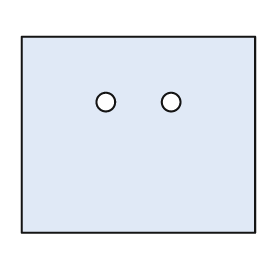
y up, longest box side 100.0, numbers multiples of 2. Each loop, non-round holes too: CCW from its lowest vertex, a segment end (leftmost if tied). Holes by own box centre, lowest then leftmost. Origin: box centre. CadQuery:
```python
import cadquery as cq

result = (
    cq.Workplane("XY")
    .moveTo(-50.0, -42.0)
    .lineTo(50.0, -42.0)
    .lineTo(50.0, 42.0)
    .lineTo(-50.0, 42.0)
    .close()
    .moveTo(-14.0, 14.0)
    .circle(4.0)
    .moveTo(14.0, 14.0)
    .circle(4.0)
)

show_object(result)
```